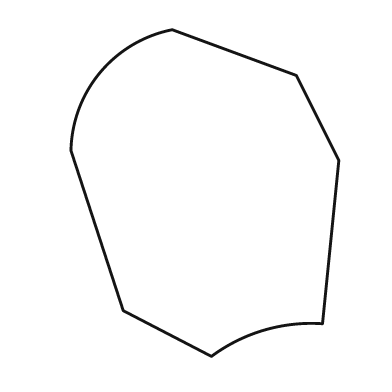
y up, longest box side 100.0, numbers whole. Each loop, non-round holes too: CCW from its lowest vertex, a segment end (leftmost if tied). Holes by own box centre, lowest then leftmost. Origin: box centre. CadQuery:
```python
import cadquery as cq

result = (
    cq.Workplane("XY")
    .moveTo(2.0, -50.0)
    .threePointArc((18.0, -42.0), (36.0, -40.0))
    .lineTo(41.0, 10.0)
    .lineTo(28.0, 36.0)
    .lineTo(-10.0, 50.0)
    .threePointArc((-32.0, 37.0), (-41.0, 13.0))
    .lineTo(-25.0, -36.0)
    .close()
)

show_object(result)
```